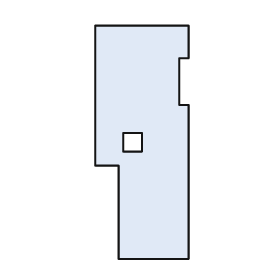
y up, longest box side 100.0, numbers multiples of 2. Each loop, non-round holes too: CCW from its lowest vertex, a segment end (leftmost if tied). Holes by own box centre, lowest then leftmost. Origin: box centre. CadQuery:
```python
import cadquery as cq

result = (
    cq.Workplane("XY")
    .moveTo(-10.0, -50.0)
    .lineTo(20.0, -50.0)
    .lineTo(20.0, 16.0)
    .lineTo(16.0, 16.0)
    .lineTo(16.0, 36.0)
    .lineTo(20.0, 36.0)
    .lineTo(20.0, 50.0)
    .lineTo(-20.0, 50.0)
    .lineTo(-20.0, -10.0)
    .lineTo(-10.0, -10.0)
    .close()
    .moveTo(-8.0, -4.0)
    .lineTo(0.0, -4.0)
    .lineTo(0.0, 4.0)
    .lineTo(-8.0, 4.0)
    .close()
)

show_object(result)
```